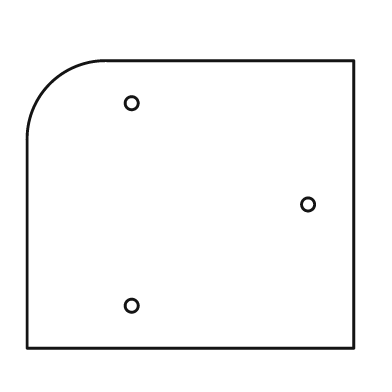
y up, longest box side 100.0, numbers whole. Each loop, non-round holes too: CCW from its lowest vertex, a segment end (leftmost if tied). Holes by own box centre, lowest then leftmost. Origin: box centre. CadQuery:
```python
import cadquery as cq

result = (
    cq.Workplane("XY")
    .moveTo(-50.0, -44.0)
    .lineTo(50.0, -44.0)
    .lineTo(50.0, 44.0)
    .lineTo(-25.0, 44.0)
    .threePointArc((-43.0, 37.0), (-50.0, 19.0))
    .close()
    .moveTo(-18.0, -31.0)
    .circle(2.0)
    .moveTo(36.0, 0.0)
    .circle(2.0)
    .moveTo(-18.0, 31.0)
    .circle(2.0)
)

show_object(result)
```